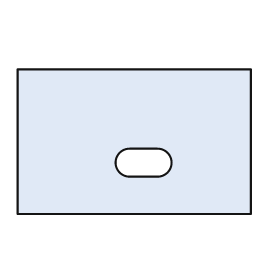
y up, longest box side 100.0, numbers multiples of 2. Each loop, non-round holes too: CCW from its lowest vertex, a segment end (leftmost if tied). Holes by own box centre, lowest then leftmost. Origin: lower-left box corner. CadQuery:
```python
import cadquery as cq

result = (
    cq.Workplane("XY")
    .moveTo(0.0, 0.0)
    .lineTo(100.0, 0.0)
    .lineTo(100.0, 62.0)
    .lineTo(0.0, 62.0)
    .close()
    .moveTo(48.0, 16.0)
    .lineTo(60.0, 16.0)
    .threePointArc((66.0, 22.0), (60.0, 28.0))
    .lineTo(48.0, 28.0)
    .threePointArc((42.0, 22.0), (48.0, 16.0))
    .close()
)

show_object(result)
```